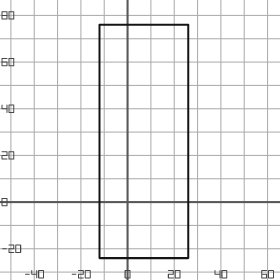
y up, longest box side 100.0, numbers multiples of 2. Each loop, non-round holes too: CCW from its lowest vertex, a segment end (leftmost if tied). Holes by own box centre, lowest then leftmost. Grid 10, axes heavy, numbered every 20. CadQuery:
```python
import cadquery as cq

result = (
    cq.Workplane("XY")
    .moveTo(-12.0, -24.0)
    .lineTo(26.0, -24.0)
    .lineTo(26.0, 76.0)
    .lineTo(-12.0, 76.0)
    .close()
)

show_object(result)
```